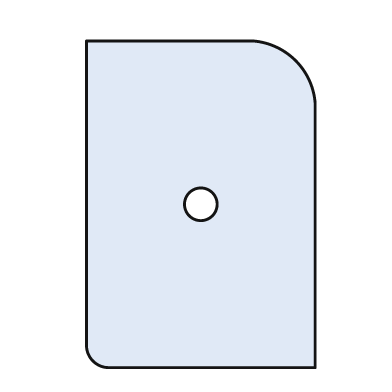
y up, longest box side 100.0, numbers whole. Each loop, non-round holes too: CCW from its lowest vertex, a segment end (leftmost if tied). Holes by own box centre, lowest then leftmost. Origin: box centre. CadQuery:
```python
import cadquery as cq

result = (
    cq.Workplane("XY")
    .moveTo(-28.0, -50.0)
    .lineTo(35.0, -50.0)
    .lineTo(35.0, 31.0)
    .threePointArc((29.0, 44.0), (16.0, 50.0))
    .lineTo(-35.0, 50.0)
    .lineTo(-35.0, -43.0)
    .threePointArc((-33.0, -48.0), (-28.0, -50.0))
    .close()
    .moveTo(0.0, 0.0)
    .circle(5.0)
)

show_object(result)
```